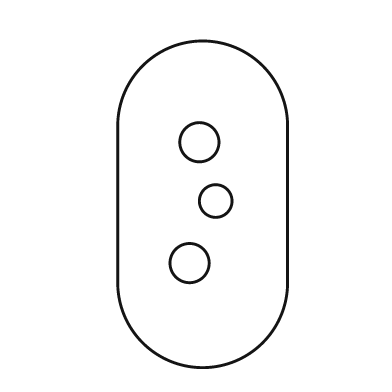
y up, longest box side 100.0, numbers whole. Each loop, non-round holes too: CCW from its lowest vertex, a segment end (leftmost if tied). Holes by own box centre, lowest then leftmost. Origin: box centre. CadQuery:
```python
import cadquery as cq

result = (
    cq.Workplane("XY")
    .moveTo(-26.0, -24.0)
    .threePointArc((0.0, -50.0), (26.0, -24.0))
    .lineTo(26.0, 24.0)
    .threePointArc((0.0, 50.0), (-26.0, 24.0))
    .close()
    .moveTo(-4.0, -18.0)
    .circle(6.0)
    .moveTo(4.0, 1.0)
    .circle(5.0)
    .moveTo(-1.0, 19.0)
    .circle(6.0)
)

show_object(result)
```